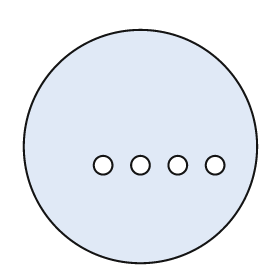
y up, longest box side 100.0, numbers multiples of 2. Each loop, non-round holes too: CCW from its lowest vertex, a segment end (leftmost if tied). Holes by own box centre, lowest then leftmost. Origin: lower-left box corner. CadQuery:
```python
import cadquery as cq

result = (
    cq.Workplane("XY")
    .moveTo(50.0, 50.0)
    .circle(50.0)
    .moveTo(34.0, 42.0)
    .circle(4.0)
    .moveTo(50.0, 42.0)
    .circle(4.0)
    .moveTo(66.0, 42.0)
    .circle(4.0)
    .moveTo(82.0, 42.0)
    .circle(4.0)
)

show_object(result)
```